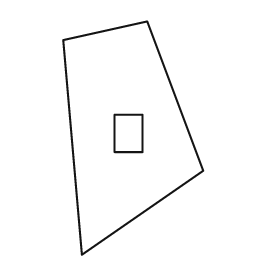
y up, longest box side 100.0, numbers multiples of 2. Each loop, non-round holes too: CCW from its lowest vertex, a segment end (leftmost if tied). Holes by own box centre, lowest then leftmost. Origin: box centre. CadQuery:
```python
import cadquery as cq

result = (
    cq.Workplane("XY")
    .moveTo(-22.0, -50.0)
    .lineTo(30.0, -14.0)
    .lineTo(6.0, 50.0)
    .lineTo(-30.0, 42.0)
    .close()
    .moveTo(-8.0, -6.0)
    .lineTo(4.0, -6.0)
    .lineTo(4.0, 10.0)
    .lineTo(-8.0, 10.0)
    .close()
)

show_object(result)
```